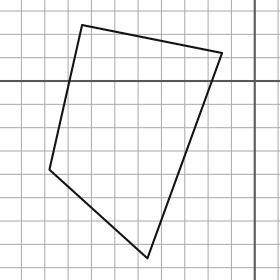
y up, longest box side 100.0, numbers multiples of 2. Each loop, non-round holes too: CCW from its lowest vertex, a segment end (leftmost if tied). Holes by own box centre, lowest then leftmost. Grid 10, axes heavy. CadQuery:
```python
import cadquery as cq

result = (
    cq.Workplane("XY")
    .moveTo(-46.0, -76.0)
    .lineTo(-14.0, 12.0)
    .lineTo(-74.0, 24.0)
    .lineTo(-88.0, -38.0)
    .close()
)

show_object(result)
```